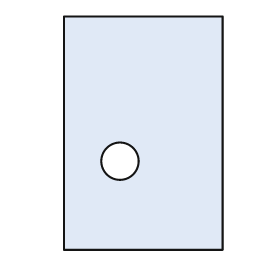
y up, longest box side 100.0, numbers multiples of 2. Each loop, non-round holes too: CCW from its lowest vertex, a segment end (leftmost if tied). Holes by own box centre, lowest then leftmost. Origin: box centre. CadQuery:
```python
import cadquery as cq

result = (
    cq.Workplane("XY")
    .moveTo(-34.0, -50.0)
    .lineTo(34.0, -50.0)
    .lineTo(34.0, 50.0)
    .lineTo(-34.0, 50.0)
    .close()
    .moveTo(-10.0, -12.0)
    .circle(8.0)
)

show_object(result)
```